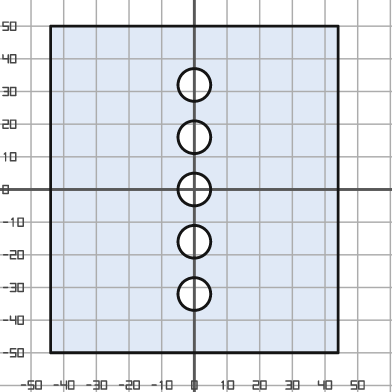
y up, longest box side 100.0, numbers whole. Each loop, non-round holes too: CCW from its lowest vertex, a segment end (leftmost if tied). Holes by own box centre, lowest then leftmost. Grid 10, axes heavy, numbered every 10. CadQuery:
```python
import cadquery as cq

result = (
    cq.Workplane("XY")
    .moveTo(-44.0, -50.0)
    .lineTo(44.0, -50.0)
    .lineTo(44.0, 50.0)
    .lineTo(-44.0, 50.0)
    .close()
    .moveTo(0.0, -32.0)
    .circle(5.0)
    .moveTo(0.0, -16.0)
    .circle(5.0)
    .moveTo(0.0, 0.0)
    .circle(5.0)
    .moveTo(0.0, 16.0)
    .circle(5.0)
    .moveTo(0.0, 32.0)
    .circle(5.0)
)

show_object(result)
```